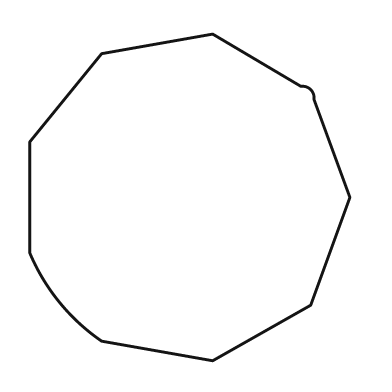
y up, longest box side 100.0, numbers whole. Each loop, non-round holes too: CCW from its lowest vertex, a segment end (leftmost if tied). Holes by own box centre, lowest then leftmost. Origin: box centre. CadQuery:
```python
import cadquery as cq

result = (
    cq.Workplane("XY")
    .moveTo(7.0, -50.0)
    .lineTo(37.0, -33.0)
    .lineTo(49.0, 0.0)
    .lineTo(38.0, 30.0)
    .threePointArc((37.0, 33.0), (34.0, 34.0))
    .lineTo(7.0, 50.0)
    .lineTo(-27.0, 44.0)
    .lineTo(-49.0, 17.0)
    .lineTo(-49.0, -17.0)
    .threePointArc((-40.0, -32.0), (-27.0, -44.0))
    .close()
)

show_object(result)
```